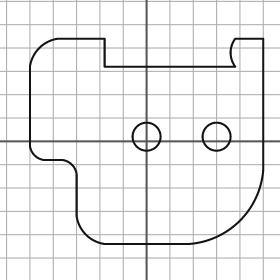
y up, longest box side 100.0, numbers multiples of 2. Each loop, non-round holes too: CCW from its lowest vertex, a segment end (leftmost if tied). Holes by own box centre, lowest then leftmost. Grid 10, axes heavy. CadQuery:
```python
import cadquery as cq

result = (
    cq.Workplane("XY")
    .moveTo(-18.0, -44.0)
    .lineTo(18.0, -44.0)
    .threePointArc((40.0, -34.0), (50.0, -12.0))
    .lineTo(50.0, 44.0)
    .lineTo(38.0, 44.0)
    .threePointArc((36.0, 38.0), (38.0, 32.0))
    .lineTo(-18.0, 32.0)
    .lineTo(-18.0, 44.0)
    .lineTo(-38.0, 44.0)
    .threePointArc((-46.0, 40.0), (-50.0, 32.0))
    .lineTo(-50.0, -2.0)
    .threePointArc((-48.0, -6.0), (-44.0, -8.0))
    .lineTo(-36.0, -8.0)
    .threePointArc((-32.0, -10.0), (-30.0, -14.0))
    .lineTo(-30.0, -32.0)
    .threePointArc((-26.0, -40.0), (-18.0, -44.0))
    .close()
    .moveTo(0.0, 2.0)
    .circle(6.0)
    .moveTo(30.0, 2.0)
    .circle(6.0)
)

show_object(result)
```